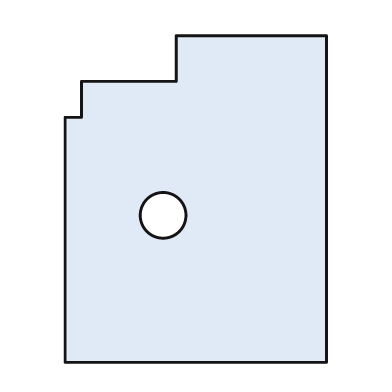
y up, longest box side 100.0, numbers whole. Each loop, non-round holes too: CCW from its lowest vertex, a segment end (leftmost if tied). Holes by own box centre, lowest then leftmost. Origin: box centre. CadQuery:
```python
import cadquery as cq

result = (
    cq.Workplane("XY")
    .moveTo(-40.0, -50.0)
    .lineTo(40.0, -50.0)
    .lineTo(40.0, 50.0)
    .lineTo(-6.0, 50.0)
    .lineTo(-6.0, 36.0)
    .lineTo(-35.0, 36.0)
    .lineTo(-35.0, 25.0)
    .lineTo(-40.0, 25.0)
    .close()
    .moveTo(-10.0, -5.0)
    .circle(7.0)
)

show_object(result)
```